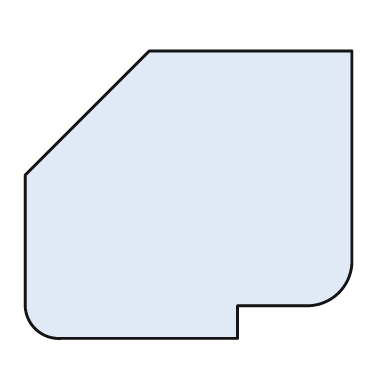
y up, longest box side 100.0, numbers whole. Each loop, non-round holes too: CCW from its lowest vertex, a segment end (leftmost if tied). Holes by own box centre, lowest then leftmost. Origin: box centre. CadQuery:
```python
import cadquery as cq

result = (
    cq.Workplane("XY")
    .moveTo(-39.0, -44.0)
    .lineTo(15.0, -44.0)
    .lineTo(15.0, -34.0)
    .lineTo(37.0, -34.0)
    .threePointArc((46.0, -30.0), (50.0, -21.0))
    .lineTo(50.0, 44.0)
    .lineTo(-12.0, 44.0)
    .lineTo(-50.0, 6.0)
    .lineTo(-50.0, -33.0)
    .threePointArc((-47.0, -41.0), (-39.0, -44.0))
    .close()
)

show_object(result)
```